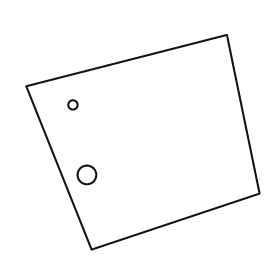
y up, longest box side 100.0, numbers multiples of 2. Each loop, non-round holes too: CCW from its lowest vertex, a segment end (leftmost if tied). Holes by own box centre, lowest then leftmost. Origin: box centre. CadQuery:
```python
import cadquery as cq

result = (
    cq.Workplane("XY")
    .moveTo(-22.0, -46.0)
    .lineTo(50.0, -22.0)
    .lineTo(36.0, 46.0)
    .lineTo(-50.0, 24.0)
    .close()
    .moveTo(-24.0, -14.0)
    .circle(4.0)
    .moveTo(-30.0, 16.0)
    .circle(2.0)
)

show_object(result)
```